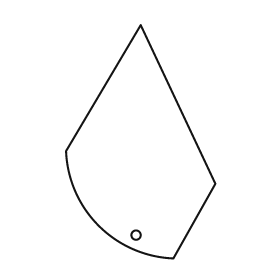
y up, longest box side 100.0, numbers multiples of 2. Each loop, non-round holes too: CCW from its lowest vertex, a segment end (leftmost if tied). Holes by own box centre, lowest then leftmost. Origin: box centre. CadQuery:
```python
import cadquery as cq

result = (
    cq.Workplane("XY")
    .moveTo(14.0, -50.0)
    .lineTo(32.0, -18.0)
    .lineTo(0.0, 50.0)
    .lineTo(-32.0, -4.0)
    .threePointArc((-18.0, -36.0), (14.0, -50.0))
    .close()
    .moveTo(-2.0, -40.0)
    .circle(2.0)
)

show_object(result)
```